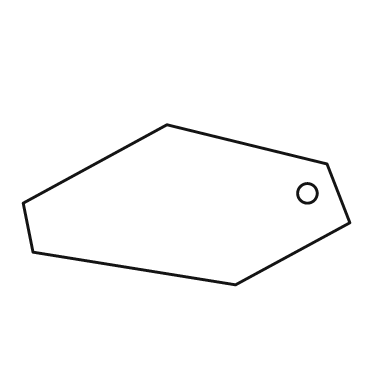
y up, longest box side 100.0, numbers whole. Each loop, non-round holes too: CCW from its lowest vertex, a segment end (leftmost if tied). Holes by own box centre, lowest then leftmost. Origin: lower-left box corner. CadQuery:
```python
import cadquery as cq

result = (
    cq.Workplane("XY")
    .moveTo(65.0, 0.0)
    .lineTo(100.0, 19.0)
    .lineTo(93.0, 37.0)
    .lineTo(44.0, 49.0)
    .lineTo(0.0, 25.0)
    .lineTo(3.0, 10.0)
    .close()
    .moveTo(87.0, 28.0)
    .circle(3.0)
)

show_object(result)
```